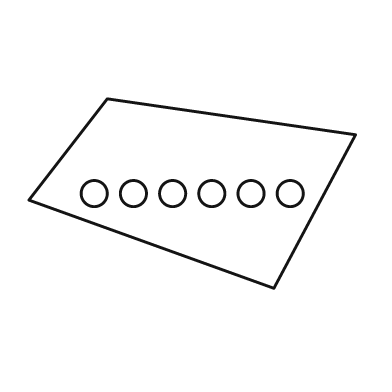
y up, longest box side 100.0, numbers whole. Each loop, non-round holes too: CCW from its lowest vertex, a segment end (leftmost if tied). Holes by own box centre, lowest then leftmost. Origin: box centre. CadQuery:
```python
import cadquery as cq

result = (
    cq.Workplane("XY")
    .moveTo(25.0, -29.0)
    .lineTo(50.0, 18.0)
    .lineTo(-26.0, 29.0)
    .lineTo(-50.0, -2.0)
    .close()
    .moveTo(-30.0, 0.0)
    .circle(4.0)
    .moveTo(-18.0, 0.0)
    .circle(4.0)
    .moveTo(-6.0, 0.0)
    .circle(4.0)
    .moveTo(6.0, 0.0)
    .circle(4.0)
    .moveTo(18.0, 0.0)
    .circle(4.0)
    .moveTo(30.0, 0.0)
    .circle(4.0)
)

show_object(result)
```